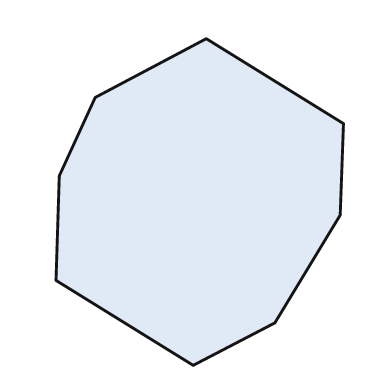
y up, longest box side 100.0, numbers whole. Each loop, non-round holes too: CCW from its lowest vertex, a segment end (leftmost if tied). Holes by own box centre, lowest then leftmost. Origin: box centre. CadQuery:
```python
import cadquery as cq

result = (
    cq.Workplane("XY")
    .moveTo(-2.0, -50.0)
    .lineTo(23.0, -37.0)
    .lineTo(43.0, -4.0)
    .lineTo(44.0, 24.0)
    .lineTo(2.0, 50.0)
    .lineTo(-32.0, 32.0)
    .lineTo(-43.0, 8.0)
    .lineTo(-44.0, -24.0)
    .close()
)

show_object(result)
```